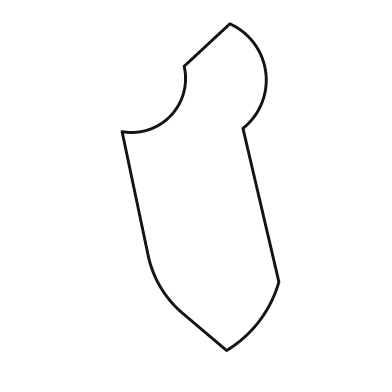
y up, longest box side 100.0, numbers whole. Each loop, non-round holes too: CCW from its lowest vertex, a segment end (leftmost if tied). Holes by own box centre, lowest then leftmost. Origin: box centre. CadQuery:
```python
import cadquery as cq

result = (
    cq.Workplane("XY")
    .moveTo(8.0, -50.0)
    .threePointArc((18.0, -41.0), (24.0, -29.0))
    .lineTo(13.0, 18.0)
    .threePointArc((20.0, 35.0), (9.0, 50.0))
    .lineTo(-5.0, 37.0)
    .threePointArc((-9.0, 22.0), (-24.0, 17.0))
    .lineTo(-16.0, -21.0)
    .threePointArc((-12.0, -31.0), (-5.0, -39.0))
    .close()
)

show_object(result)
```